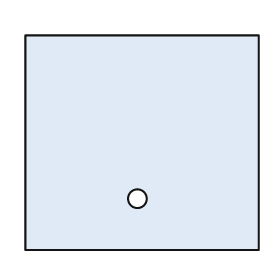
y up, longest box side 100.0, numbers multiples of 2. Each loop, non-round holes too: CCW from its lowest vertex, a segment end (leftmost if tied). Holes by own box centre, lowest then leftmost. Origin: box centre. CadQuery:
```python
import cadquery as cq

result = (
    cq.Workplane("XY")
    .moveTo(-50.0, -46.0)
    .lineTo(50.0, -46.0)
    .lineTo(50.0, 46.0)
    .lineTo(-50.0, 46.0)
    .close()
    .moveTo(-2.0, -24.0)
    .circle(4.0)
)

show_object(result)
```